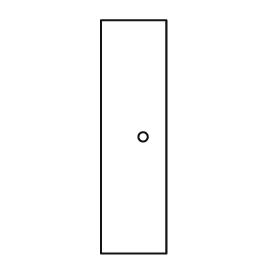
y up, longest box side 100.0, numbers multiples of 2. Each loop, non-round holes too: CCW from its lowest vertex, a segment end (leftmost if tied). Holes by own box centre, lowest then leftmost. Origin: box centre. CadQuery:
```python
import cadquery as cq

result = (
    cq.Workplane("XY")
    .moveTo(-14.0, -50.0)
    .lineTo(14.0, -50.0)
    .lineTo(14.0, 50.0)
    .lineTo(-14.0, 50.0)
    .close()
    .moveTo(4.0, 0.0)
    .circle(2.0)
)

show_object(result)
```